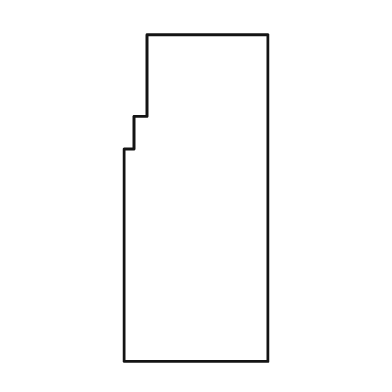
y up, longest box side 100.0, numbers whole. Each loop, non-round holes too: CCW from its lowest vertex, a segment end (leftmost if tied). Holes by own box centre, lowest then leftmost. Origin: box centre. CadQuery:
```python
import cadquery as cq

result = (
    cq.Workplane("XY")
    .moveTo(-22.0, -50.0)
    .lineTo(22.0, -50.0)
    .lineTo(22.0, 50.0)
    .lineTo(-15.0, 50.0)
    .lineTo(-15.0, 25.0)
    .lineTo(-19.0, 25.0)
    .lineTo(-19.0, 15.0)
    .lineTo(-22.0, 15.0)
    .close()
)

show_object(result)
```